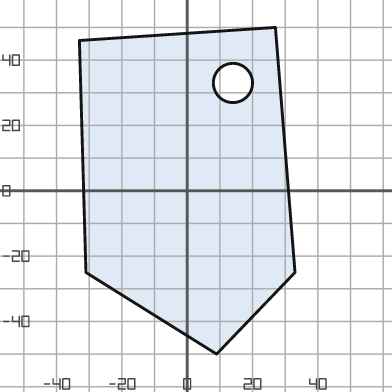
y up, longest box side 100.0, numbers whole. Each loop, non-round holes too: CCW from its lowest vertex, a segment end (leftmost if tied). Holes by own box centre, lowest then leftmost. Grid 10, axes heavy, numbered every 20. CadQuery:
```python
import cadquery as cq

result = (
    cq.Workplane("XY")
    .moveTo(9.0, -50.0)
    .lineTo(33.0, -25.0)
    .lineTo(27.0, 50.0)
    .lineTo(-33.0, 46.0)
    .lineTo(-31.0, -25.0)
    .close()
    .moveTo(14.0, 33.0)
    .circle(6.0)
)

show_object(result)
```